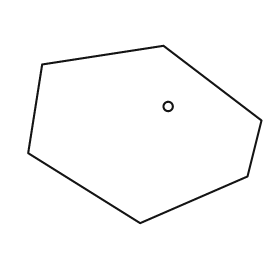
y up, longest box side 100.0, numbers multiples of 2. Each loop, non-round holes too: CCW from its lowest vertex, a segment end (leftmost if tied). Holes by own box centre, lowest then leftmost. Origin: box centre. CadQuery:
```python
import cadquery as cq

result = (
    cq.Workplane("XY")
    .moveTo(-2.0, -38.0)
    .lineTo(44.0, -18.0)
    .lineTo(50.0, 6.0)
    .lineTo(8.0, 38.0)
    .lineTo(-44.0, 30.0)
    .lineTo(-50.0, -8.0)
    .close()
    .moveTo(10.0, 12.0)
    .circle(2.0)
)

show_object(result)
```